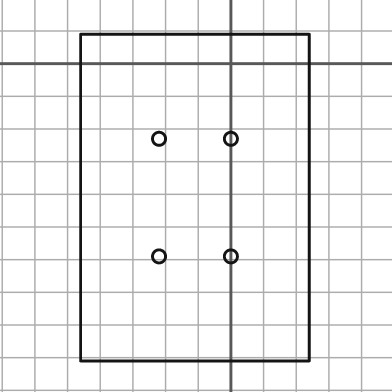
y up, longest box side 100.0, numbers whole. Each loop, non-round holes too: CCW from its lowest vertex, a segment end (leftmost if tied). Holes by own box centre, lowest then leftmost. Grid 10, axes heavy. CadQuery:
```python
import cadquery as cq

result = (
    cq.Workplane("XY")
    .moveTo(-46.0, -91.0)
    .lineTo(24.0, -91.0)
    .lineTo(24.0, 9.0)
    .lineTo(-46.0, 9.0)
    .close()
    .moveTo(-22.0, -59.0)
    .circle(2.0)
    .moveTo(0.0, -59.0)
    .circle(2.0)
    .moveTo(-22.0, -23.0)
    .circle(2.0)
    .moveTo(0.0, -23.0)
    .circle(2.0)
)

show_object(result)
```